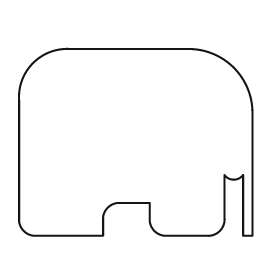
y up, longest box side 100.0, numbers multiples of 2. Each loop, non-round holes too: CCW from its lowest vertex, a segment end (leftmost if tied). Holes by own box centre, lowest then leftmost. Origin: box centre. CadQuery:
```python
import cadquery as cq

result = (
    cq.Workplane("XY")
    .moveTo(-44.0, -40.0)
    .lineTo(-14.0, -40.0)
    .lineTo(-14.0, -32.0)
    .threePointArc((-12.0, -28.0), (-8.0, -26.0))
    .lineTo(6.0, -26.0)
    .lineTo(6.0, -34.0)
    .threePointArc((8.0, -38.0), (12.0, -40.0))
    .lineTo(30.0, -40.0)
    .threePointArc((36.0, -38.0), (38.0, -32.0))
    .lineTo(38.0, -14.0)
    .threePointArc((42.0, -16.0), (46.0, -14.0))
    .lineTo(46.0, -40.0)
    .lineTo(50.0, -40.0)
    .lineTo(50.0, 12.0)
    .threePointArc((42.0, 32.0), (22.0, 40.0))
    .lineTo(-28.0, 40.0)
    .threePointArc((-44.0, 34.0), (-50.0, 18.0))
    .lineTo(-50.0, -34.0)
    .threePointArc((-48.0, -38.0), (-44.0, -40.0))
    .close()
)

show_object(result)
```